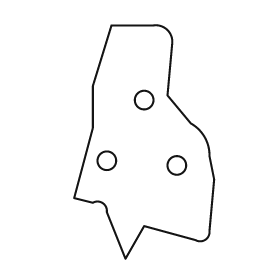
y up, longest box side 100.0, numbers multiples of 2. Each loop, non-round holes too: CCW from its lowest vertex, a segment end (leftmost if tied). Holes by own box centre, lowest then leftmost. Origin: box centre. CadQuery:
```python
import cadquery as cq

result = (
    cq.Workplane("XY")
    .moveTo(-8.0, -50.0)
    .lineTo(0.0, -36.0)
    .lineTo(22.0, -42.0)
    .threePointArc((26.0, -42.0), (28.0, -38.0))
    .lineTo(30.0, -16.0)
    .lineTo(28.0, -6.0)
    .threePointArc((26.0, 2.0), (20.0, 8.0))
    .lineTo(10.0, 20.0)
    .lineTo(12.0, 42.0)
    .threePointArc((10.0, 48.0), (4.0, 50.0))
    .lineTo(-14.0, 50.0)
    .lineTo(-22.0, 24.0)
    .lineTo(-22.0, 6.0)
    .lineTo(-30.0, -24.0)
    .lineTo(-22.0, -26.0)
    .threePointArc((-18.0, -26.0), (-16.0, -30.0))
    .close()
    .moveTo(14.0, -10.0)
    .circle(4.0)
    .moveTo(-16.0, -8.0)
    .circle(4.0)
    .moveTo(0.0, 18.0)
    .circle(4.0)
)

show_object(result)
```